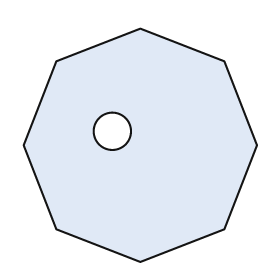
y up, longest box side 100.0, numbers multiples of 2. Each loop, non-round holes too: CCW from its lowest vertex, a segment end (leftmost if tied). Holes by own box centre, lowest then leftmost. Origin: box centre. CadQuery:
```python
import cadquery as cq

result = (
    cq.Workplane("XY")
    .moveTo(0.0, -50.0)
    .lineTo(36.0, -36.0)
    .lineTo(50.0, 0.0)
    .lineTo(36.0, 36.0)
    .lineTo(0.0, 50.0)
    .lineTo(-36.0, 36.0)
    .lineTo(-50.0, 0.0)
    .lineTo(-36.0, -36.0)
    .close()
    .moveTo(-12.0, 6.0)
    .circle(8.0)
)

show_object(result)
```